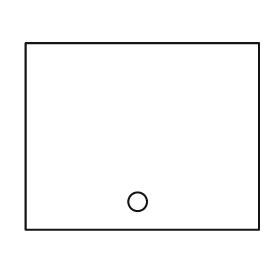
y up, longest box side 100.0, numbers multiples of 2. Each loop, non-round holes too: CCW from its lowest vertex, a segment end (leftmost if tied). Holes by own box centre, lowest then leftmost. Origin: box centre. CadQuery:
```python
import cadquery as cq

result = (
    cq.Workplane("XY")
    .moveTo(-50.0, -40.0)
    .lineTo(50.0, -40.0)
    .lineTo(50.0, 40.0)
    .lineTo(-50.0, 40.0)
    .close()
    .moveTo(-2.0, -28.0)
    .circle(4.0)
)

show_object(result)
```